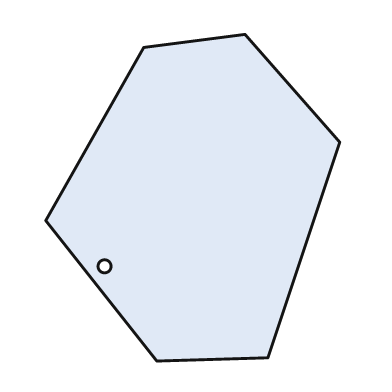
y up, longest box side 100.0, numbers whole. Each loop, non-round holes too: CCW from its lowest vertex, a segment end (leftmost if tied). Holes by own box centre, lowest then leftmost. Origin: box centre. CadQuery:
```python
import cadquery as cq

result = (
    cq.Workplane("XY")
    .moveTo(-11.0, -50.0)
    .lineTo(23.0, -49.0)
    .lineTo(45.0, 17.0)
    .lineTo(16.0, 50.0)
    .lineTo(-15.0, 46.0)
    .lineTo(-45.0, -7.0)
    .close()
    .moveTo(-27.0, -21.0)
    .circle(2.0)
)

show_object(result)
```